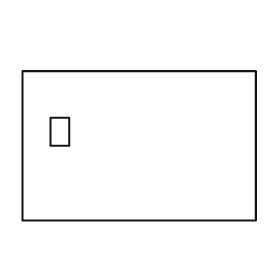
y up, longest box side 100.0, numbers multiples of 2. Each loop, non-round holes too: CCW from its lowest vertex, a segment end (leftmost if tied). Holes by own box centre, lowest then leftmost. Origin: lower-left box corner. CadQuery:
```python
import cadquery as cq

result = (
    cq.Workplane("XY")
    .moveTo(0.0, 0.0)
    .lineTo(100.0, 0.0)
    .lineTo(100.0, 64.0)
    .lineTo(0.0, 64.0)
    .close()
    .moveTo(12.0, 32.0)
    .lineTo(20.0, 32.0)
    .lineTo(20.0, 44.0)
    .lineTo(12.0, 44.0)
    .close()
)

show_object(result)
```